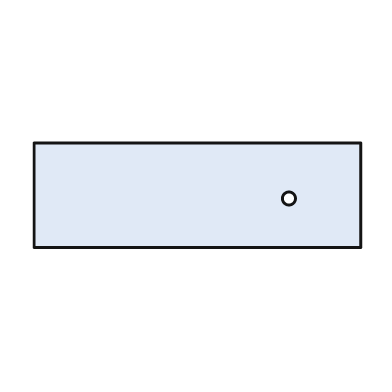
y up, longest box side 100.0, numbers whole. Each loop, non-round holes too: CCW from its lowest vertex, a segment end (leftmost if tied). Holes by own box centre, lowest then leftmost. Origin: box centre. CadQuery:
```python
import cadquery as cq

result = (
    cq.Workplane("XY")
    .moveTo(-50.0, -16.0)
    .lineTo(50.0, -16.0)
    .lineTo(50.0, 16.0)
    .lineTo(-50.0, 16.0)
    .close()
    .moveTo(28.0, -1.0)
    .circle(2.0)
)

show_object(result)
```